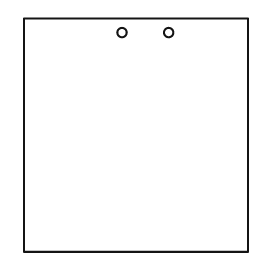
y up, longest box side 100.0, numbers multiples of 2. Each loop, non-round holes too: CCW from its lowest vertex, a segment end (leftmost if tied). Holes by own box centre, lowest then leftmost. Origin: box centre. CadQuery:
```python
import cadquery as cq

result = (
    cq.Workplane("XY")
    .moveTo(-48.0, -50.0)
    .lineTo(48.0, -50.0)
    .lineTo(48.0, 50.0)
    .lineTo(-48.0, 50.0)
    .close()
    .moveTo(-6.0, 44.0)
    .circle(2.0)
    .moveTo(14.0, 44.0)
    .circle(2.0)
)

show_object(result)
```